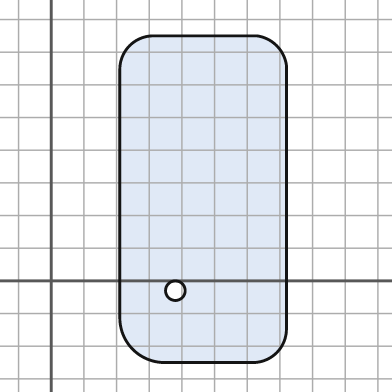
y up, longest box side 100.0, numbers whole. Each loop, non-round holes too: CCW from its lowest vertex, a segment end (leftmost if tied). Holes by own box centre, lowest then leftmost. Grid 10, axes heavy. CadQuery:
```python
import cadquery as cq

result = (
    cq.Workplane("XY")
    .moveTo(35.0, -25.0)
    .lineTo(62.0, -25.0)
    .threePointArc((69.0, -22.0), (72.0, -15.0))
    .lineTo(72.0, 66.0)
    .threePointArc((69.0, 72.0), (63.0, 75.0))
    .lineTo(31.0, 75.0)
    .threePointArc((24.0, 72.0), (21.0, 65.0))
    .lineTo(21.0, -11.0)
    .threePointArc((25.0, -21.0), (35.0, -25.0))
    .close()
    .moveTo(38.0, -3.0)
    .circle(3.0)
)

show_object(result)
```